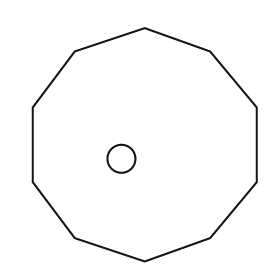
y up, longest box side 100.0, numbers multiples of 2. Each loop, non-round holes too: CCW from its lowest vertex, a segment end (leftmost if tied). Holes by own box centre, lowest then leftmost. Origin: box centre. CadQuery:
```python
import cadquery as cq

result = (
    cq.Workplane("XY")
    .moveTo(0.0, -50.0)
    .lineTo(28.0, -40.0)
    .lineTo(48.0, -16.0)
    .lineTo(48.0, 16.0)
    .lineTo(28.0, 40.0)
    .lineTo(0.0, 50.0)
    .lineTo(-30.0, 40.0)
    .lineTo(-48.0, 16.0)
    .lineTo(-48.0, -16.0)
    .lineTo(-30.0, -40.0)
    .close()
    .moveTo(-10.0, -6.0)
    .circle(6.0)
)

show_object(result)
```